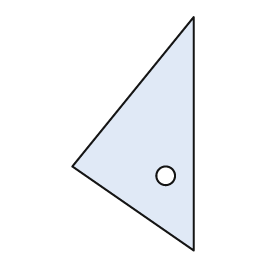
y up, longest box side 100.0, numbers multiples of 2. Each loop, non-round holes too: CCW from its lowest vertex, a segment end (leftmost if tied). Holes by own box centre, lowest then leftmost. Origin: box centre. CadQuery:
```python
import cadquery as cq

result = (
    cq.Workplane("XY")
    .moveTo(26.0, -50.0)
    .lineTo(26.0, 50.0)
    .lineTo(-26.0, -14.0)
    .close()
    .moveTo(14.0, -18.0)
    .circle(4.0)
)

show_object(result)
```